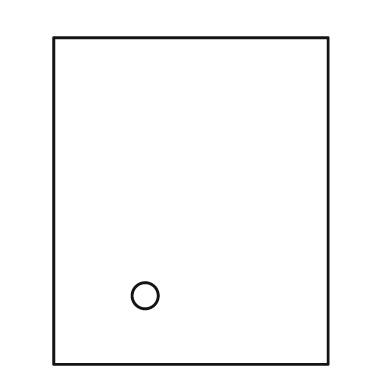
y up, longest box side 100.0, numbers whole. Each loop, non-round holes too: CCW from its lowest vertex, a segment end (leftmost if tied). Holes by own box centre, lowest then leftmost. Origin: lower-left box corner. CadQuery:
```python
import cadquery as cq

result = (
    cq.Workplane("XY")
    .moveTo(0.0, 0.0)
    .lineTo(84.0, 0.0)
    .lineTo(84.0, 100.0)
    .lineTo(0.0, 100.0)
    .close()
    .moveTo(28.0, 21.0)
    .circle(4.0)
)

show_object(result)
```